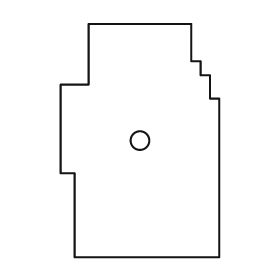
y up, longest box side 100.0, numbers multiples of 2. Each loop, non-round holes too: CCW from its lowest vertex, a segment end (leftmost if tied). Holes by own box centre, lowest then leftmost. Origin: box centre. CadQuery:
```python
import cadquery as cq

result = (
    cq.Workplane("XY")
    .moveTo(-28.0, -50.0)
    .lineTo(34.0, -50.0)
    .lineTo(34.0, 18.0)
    .lineTo(30.0, 18.0)
    .lineTo(30.0, 28.0)
    .lineTo(26.0, 28.0)
    .lineTo(26.0, 34.0)
    .lineTo(22.0, 34.0)
    .lineTo(22.0, 50.0)
    .lineTo(-22.0, 50.0)
    .lineTo(-22.0, 24.0)
    .lineTo(-34.0, 24.0)
    .lineTo(-34.0, -14.0)
    .lineTo(-28.0, -14.0)
    .close()
    .moveTo(0.0, 0.0)
    .circle(4.0)
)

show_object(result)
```